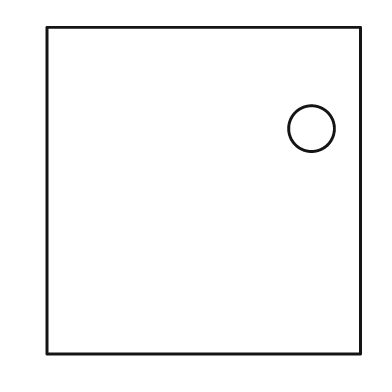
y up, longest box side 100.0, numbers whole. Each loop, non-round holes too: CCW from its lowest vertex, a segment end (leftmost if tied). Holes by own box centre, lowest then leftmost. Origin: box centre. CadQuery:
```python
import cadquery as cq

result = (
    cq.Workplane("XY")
    .moveTo(-48.0, -50.0)
    .lineTo(48.0, -50.0)
    .lineTo(48.0, 50.0)
    .lineTo(-48.0, 50.0)
    .close()
    .moveTo(33.0, 19.0)
    .circle(7.0)
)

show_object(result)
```